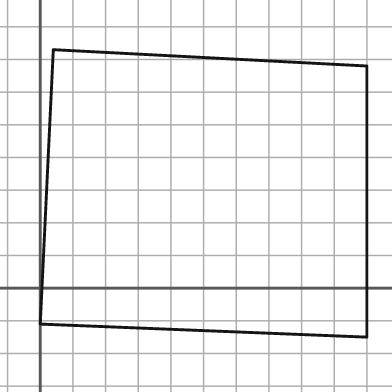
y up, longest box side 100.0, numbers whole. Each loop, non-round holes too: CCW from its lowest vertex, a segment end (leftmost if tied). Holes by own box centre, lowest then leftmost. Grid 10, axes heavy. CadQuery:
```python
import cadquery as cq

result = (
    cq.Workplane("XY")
    .moveTo(100.0, -15.0)
    .lineTo(100.0, 68.0)
    .lineTo(4.0, 73.0)
    .lineTo(0.0, -11.0)
    .close()
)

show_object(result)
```